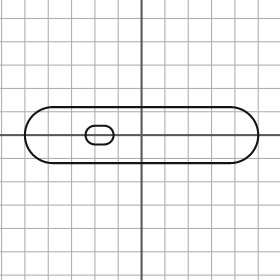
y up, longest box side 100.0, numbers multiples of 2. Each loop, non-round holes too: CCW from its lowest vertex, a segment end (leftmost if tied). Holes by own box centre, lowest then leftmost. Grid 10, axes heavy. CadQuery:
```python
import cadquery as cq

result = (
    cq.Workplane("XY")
    .moveTo(-38.0, -12.0)
    .lineTo(38.0, -12.0)
    .threePointArc((50.0, 0.0), (38.0, 12.0))
    .lineTo(-38.0, 12.0)
    .threePointArc((-50.0, 0.0), (-38.0, -12.0))
    .close()
    .moveTo(-20.0, -4.0)
    .lineTo(-16.0, -4.0)
    .threePointArc((-12.0, 0.0), (-16.0, 4.0))
    .lineTo(-20.0, 4.0)
    .threePointArc((-24.0, 0.0), (-20.0, -4.0))
    .close()
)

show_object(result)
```